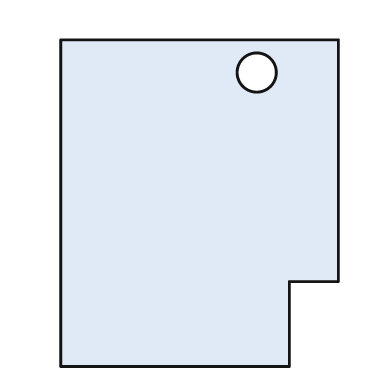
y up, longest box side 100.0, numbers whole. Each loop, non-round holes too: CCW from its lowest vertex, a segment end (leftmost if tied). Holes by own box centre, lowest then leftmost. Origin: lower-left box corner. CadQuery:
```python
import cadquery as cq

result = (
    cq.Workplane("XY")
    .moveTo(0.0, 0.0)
    .lineTo(70.0, 0.0)
    .lineTo(70.0, 26.0)
    .lineTo(85.0, 26.0)
    .lineTo(85.0, 100.0)
    .lineTo(0.0, 100.0)
    .close()
    .moveTo(60.0, 90.0)
    .circle(6.0)
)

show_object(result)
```